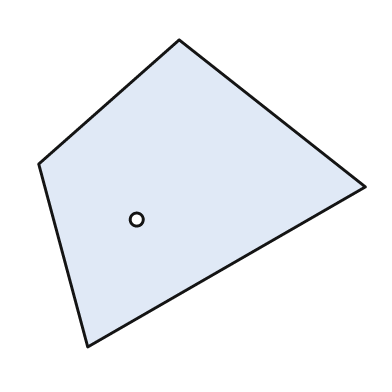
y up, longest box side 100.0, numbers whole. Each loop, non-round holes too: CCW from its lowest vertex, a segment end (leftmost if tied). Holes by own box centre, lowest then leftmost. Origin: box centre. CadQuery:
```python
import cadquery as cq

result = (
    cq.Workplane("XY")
    .moveTo(-35.0, -47.0)
    .lineTo(50.0, 2.0)
    .lineTo(-7.0, 47.0)
    .lineTo(-50.0, 9.0)
    .close()
    .moveTo(-20.0, -8.0)
    .circle(2.0)
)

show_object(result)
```